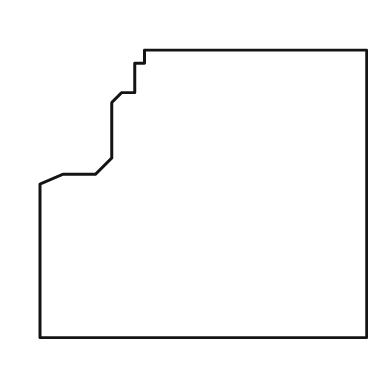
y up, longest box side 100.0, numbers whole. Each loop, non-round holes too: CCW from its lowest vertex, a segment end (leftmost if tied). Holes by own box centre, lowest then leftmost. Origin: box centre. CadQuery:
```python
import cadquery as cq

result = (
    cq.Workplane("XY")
    .moveTo(-50.0, -44.0)
    .lineTo(50.0, -44.0)
    .lineTo(50.0, 44.0)
    .lineTo(-18.0, 44.0)
    .lineTo(-18.0, 40.0)
    .lineTo(-21.0, 40.0)
    .lineTo(-21.0, 31.0)
    .lineTo(-25.0, 31.0)
    .lineTo(-28.0, 28.0)
    .lineTo(-28.0, 11.0)
    .lineTo(-33.0, 6.0)
    .lineTo(-43.0, 6.0)
    .lineTo(-50.0, 3.0)
    .close()
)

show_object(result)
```